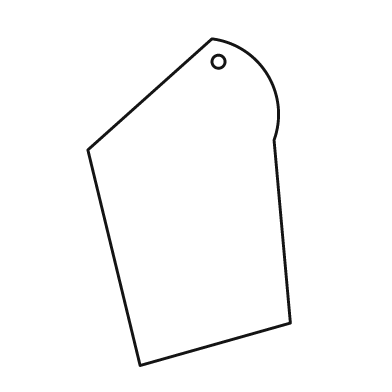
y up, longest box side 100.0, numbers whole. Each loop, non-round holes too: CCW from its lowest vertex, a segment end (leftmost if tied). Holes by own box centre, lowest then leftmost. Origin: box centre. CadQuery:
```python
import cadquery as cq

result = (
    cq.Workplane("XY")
    .moveTo(-15.0, -50.0)
    .lineTo(31.0, -37.0)
    .lineTo(26.0, 19.0)
    .threePointArc((24.0, 39.0), (7.0, 50.0))
    .lineTo(-31.0, 16.0)
    .close()
    .moveTo(9.0, 43.0)
    .circle(2.0)
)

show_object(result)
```